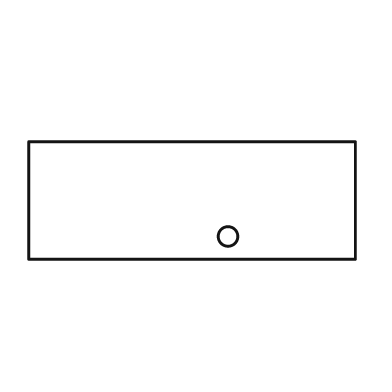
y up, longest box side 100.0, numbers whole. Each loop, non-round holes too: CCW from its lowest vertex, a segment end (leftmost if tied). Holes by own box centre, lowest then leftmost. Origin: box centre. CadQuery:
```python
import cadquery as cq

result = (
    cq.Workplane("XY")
    .moveTo(-50.0, -18.0)
    .lineTo(50.0, -18.0)
    .lineTo(50.0, 18.0)
    .lineTo(-50.0, 18.0)
    .close()
    .moveTo(11.0, -11.0)
    .circle(3.0)
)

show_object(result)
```